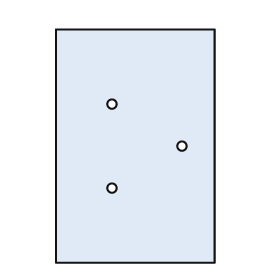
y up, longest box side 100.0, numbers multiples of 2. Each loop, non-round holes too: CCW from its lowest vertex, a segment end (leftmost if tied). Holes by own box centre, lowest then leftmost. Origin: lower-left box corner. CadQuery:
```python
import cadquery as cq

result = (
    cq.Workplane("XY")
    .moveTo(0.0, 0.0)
    .lineTo(68.0, 0.0)
    .lineTo(68.0, 100.0)
    .lineTo(0.0, 100.0)
    .close()
    .moveTo(24.0, 32.0)
    .circle(2.0)
    .moveTo(54.0, 50.0)
    .circle(2.0)
    .moveTo(24.0, 68.0)
    .circle(2.0)
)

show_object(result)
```